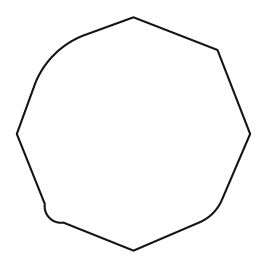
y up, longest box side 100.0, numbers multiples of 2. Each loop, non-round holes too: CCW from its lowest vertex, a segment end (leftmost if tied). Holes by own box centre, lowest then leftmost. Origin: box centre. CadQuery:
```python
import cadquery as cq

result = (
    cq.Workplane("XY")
    .moveTo(0.0, -50.0)
    .lineTo(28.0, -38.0)
    .threePointArc((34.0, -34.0), (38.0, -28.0))
    .lineTo(50.0, 0.0)
    .lineTo(36.0, 36.0)
    .lineTo(0.0, 50.0)
    .lineTo(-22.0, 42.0)
    .threePointArc((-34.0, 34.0), (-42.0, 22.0))
    .lineTo(-50.0, 0.0)
    .lineTo(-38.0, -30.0)
    .threePointArc((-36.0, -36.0), (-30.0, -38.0))
    .close()
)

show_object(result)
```